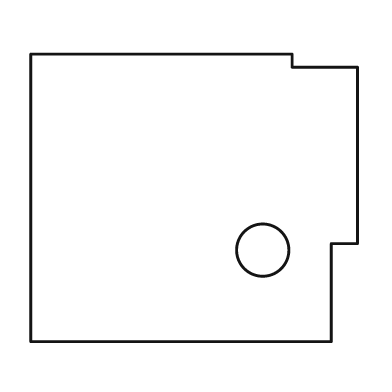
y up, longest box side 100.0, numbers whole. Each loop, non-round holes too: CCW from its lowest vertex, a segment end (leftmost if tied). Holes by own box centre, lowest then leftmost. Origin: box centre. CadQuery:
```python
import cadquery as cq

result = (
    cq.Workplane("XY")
    .moveTo(-50.0, -44.0)
    .lineTo(42.0, -44.0)
    .lineTo(42.0, -14.0)
    .lineTo(50.0, -14.0)
    .lineTo(50.0, 40.0)
    .lineTo(30.0, 40.0)
    .lineTo(30.0, 44.0)
    .lineTo(-50.0, 44.0)
    .close()
    .moveTo(21.0, -16.0)
    .circle(8.0)
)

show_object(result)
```